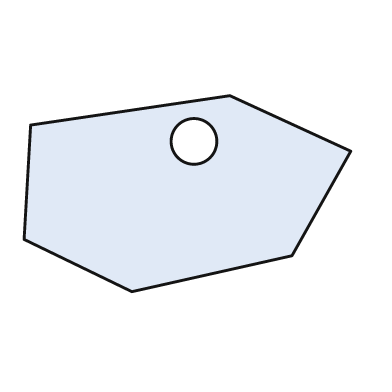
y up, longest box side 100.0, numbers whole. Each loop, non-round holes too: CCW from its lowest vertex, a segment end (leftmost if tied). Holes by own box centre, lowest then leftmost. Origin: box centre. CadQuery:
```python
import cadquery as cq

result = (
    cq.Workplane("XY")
    .moveTo(-17.0, -30.0)
    .lineTo(32.0, -19.0)
    .lineTo(50.0, 13.0)
    .lineTo(13.0, 30.0)
    .lineTo(-48.0, 21.0)
    .lineTo(-50.0, -14.0)
    .close()
    .moveTo(2.0, 16.0)
    .circle(7.0)
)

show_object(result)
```